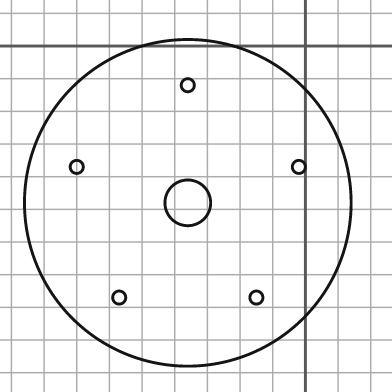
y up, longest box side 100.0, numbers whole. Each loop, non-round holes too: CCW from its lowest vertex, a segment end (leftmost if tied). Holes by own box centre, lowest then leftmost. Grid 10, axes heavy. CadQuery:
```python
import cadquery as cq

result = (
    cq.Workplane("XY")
    .moveTo(-36.0, -48.0)
    .circle(50.0)
    .moveTo(-57.0, -77.0)
    .circle(2.0)
    .moveTo(-15.0, -77.0)
    .circle(2.0)
    .moveTo(-36.0, -48.0)
    .circle(7.0)
    .moveTo(-70.0, -37.0)
    .circle(2.0)
    .moveTo(-2.0, -37.0)
    .circle(2.0)
    .moveTo(-36.0, -12.0)
    .circle(2.0)
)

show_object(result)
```